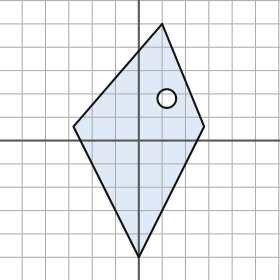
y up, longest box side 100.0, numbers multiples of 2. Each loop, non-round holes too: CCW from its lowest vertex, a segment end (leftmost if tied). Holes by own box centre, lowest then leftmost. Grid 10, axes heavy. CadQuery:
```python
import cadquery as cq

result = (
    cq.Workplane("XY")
    .moveTo(0.0, -50.0)
    .lineTo(28.0, 6.0)
    .lineTo(10.0, 50.0)
    .lineTo(-28.0, 6.0)
    .close()
    .moveTo(12.0, 18.0)
    .circle(4.0)
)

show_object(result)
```